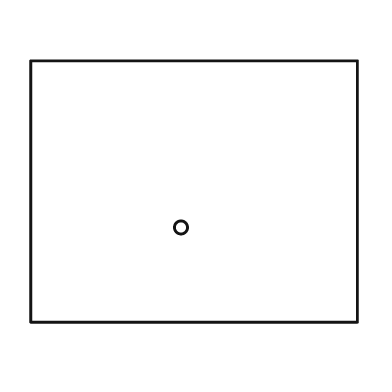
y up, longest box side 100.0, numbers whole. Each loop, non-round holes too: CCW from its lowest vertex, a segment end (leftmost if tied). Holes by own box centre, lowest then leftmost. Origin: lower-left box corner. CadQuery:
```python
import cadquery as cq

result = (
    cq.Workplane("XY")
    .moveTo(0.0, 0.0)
    .lineTo(100.0, 0.0)
    .lineTo(100.0, 80.0)
    .lineTo(0.0, 80.0)
    .close()
    .moveTo(46.0, 29.0)
    .circle(2.0)
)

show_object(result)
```